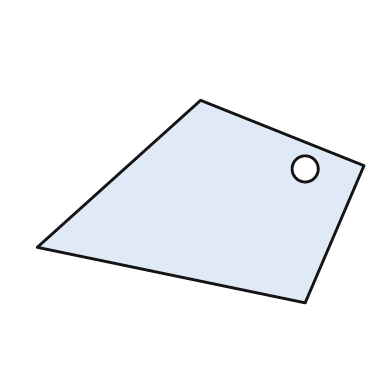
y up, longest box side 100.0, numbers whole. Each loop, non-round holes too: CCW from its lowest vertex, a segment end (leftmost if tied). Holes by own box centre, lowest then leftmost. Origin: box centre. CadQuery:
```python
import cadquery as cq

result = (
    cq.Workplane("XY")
    .moveTo(32.0, -31.0)
    .lineTo(50.0, 11.0)
    .lineTo(0.0, 31.0)
    .lineTo(-50.0, -14.0)
    .close()
    .moveTo(32.0, 10.0)
    .circle(4.0)
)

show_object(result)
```